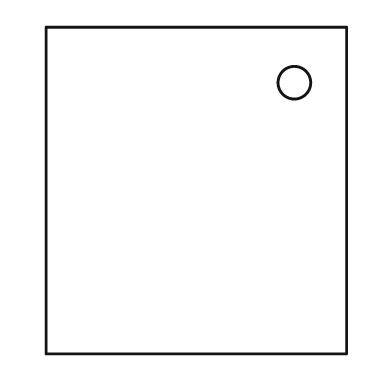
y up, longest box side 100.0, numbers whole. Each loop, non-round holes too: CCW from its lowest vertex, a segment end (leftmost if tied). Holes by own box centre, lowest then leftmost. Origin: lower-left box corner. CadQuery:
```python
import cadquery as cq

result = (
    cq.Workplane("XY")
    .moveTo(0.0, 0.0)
    .lineTo(92.0, 0.0)
    .lineTo(92.0, 100.0)
    .lineTo(0.0, 100.0)
    .close()
    .moveTo(76.0, 83.0)
    .circle(5.0)
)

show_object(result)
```